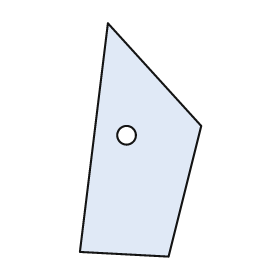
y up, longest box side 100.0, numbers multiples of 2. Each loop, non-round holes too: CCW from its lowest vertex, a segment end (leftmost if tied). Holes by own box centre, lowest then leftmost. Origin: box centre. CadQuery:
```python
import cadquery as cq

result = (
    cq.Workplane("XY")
    .moveTo(12.0, -50.0)
    .lineTo(26.0, 6.0)
    .lineTo(-14.0, 50.0)
    .lineTo(-26.0, -48.0)
    .close()
    .moveTo(-6.0, 2.0)
    .circle(4.0)
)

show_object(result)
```